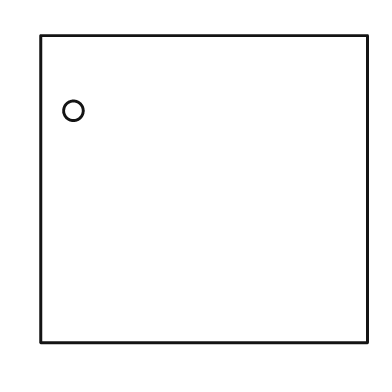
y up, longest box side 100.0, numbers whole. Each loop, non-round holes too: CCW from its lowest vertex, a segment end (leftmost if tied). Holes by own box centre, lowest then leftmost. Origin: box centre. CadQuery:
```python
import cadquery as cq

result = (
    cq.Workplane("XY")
    .moveTo(-50.0, -47.0)
    .lineTo(50.0, -47.0)
    .lineTo(50.0, 47.0)
    .lineTo(-50.0, 47.0)
    .close()
    .moveTo(-40.0, 24.0)
    .circle(3.0)
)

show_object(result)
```